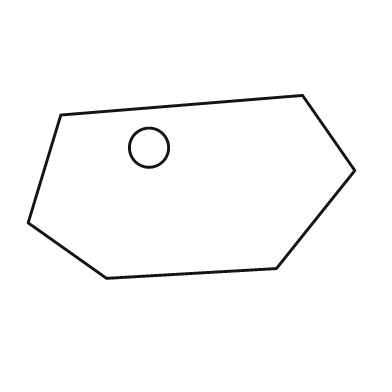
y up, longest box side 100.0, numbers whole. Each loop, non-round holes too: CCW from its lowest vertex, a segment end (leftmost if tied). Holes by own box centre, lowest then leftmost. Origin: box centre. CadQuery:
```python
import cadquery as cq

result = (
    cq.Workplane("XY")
    .moveTo(-26.0, -28.0)
    .lineTo(26.0, -25.0)
    .lineTo(50.0, 5.0)
    .lineTo(34.0, 28.0)
    .lineTo(-40.0, 22.0)
    .lineTo(-50.0, -11.0)
    .close()
    .moveTo(-13.0, 12.0)
    .circle(6.0)
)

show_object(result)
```